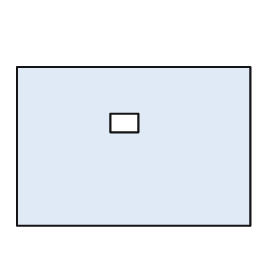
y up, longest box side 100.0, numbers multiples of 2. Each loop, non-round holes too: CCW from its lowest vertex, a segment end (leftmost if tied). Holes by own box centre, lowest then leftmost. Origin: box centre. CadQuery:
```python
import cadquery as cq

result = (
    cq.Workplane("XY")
    .moveTo(-50.0, -34.0)
    .lineTo(50.0, -34.0)
    .lineTo(50.0, 34.0)
    .lineTo(-50.0, 34.0)
    .close()
    .moveTo(-10.0, 6.0)
    .lineTo(2.0, 6.0)
    .lineTo(2.0, 14.0)
    .lineTo(-10.0, 14.0)
    .close()
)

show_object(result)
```